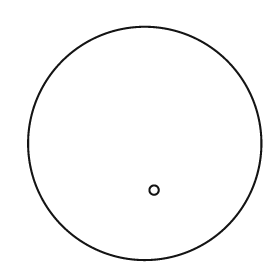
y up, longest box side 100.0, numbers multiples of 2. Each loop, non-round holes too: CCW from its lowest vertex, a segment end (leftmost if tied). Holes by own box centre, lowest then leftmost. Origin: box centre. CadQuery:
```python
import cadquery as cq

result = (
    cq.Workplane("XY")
    .moveTo(0.0, 0.0)
    .circle(50.0)
    .moveTo(4.0, -20.0)
    .circle(2.0)
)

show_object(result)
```